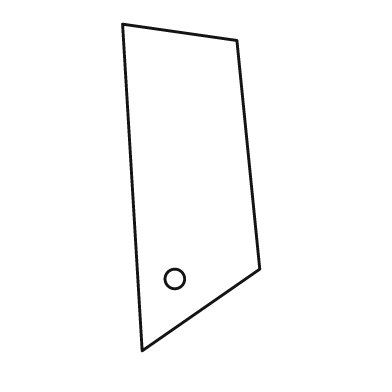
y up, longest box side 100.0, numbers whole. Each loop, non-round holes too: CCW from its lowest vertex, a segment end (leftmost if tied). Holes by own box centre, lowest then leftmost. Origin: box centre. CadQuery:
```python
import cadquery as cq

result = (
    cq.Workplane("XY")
    .moveTo(-15.0, -50.0)
    .lineTo(21.0, -25.0)
    .lineTo(14.0, 45.0)
    .lineTo(-21.0, 50.0)
    .close()
    .moveTo(-5.0, -28.0)
    .circle(3.0)
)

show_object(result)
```